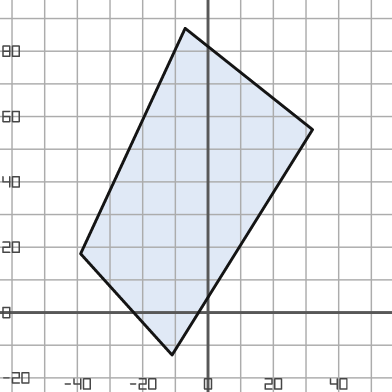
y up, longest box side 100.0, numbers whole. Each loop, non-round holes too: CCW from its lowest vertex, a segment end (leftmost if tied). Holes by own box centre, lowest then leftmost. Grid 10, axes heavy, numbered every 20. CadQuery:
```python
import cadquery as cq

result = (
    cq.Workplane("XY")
    .moveTo(-11.0, -13.0)
    .lineTo(32.0, 56.0)
    .lineTo(-7.0, 87.0)
    .lineTo(-39.0, 18.0)
    .close()
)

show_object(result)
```